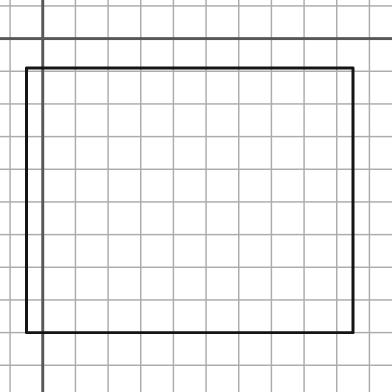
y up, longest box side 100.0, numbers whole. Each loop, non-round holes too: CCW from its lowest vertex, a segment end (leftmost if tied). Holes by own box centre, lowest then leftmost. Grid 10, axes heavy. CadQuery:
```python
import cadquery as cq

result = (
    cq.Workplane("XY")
    .moveTo(-5.0, -90.0)
    .lineTo(95.0, -90.0)
    .lineTo(95.0, -9.0)
    .lineTo(-5.0, -9.0)
    .close()
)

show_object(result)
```